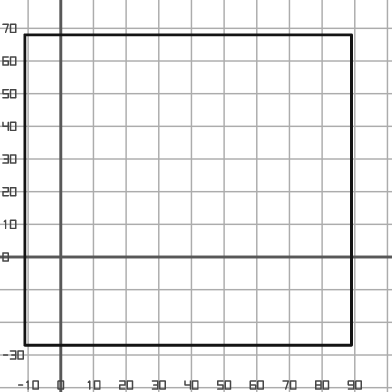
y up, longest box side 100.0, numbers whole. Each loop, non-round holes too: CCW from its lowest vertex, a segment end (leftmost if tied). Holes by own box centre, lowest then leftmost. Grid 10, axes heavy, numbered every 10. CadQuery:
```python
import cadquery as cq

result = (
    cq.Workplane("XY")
    .moveTo(-11.0, -27.0)
    .lineTo(89.0, -27.0)
    .lineTo(89.0, 68.0)
    .lineTo(-11.0, 68.0)
    .close()
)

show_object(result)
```